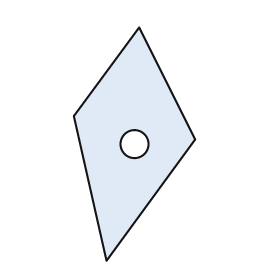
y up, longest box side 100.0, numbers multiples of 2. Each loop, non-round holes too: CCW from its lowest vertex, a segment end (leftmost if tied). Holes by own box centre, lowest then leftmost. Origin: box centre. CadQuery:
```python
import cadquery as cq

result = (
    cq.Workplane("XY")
    .moveTo(-12.0, -50.0)
    .lineTo(26.0, 2.0)
    .lineTo(2.0, 50.0)
    .lineTo(-26.0, 12.0)
    .close()
    .moveTo(0.0, 0.0)
    .circle(6.0)
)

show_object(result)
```